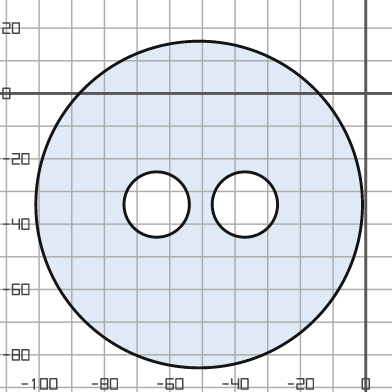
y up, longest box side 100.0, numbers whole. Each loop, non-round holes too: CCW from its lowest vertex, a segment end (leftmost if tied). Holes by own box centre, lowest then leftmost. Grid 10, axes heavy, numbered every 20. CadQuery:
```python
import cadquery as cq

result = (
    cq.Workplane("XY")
    .moveTo(-51.0, -34.0)
    .circle(50.0)
    .moveTo(-64.0, -34.0)
    .circle(10.0)
    .moveTo(-37.0, -34.0)
    .circle(10.0)
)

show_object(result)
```